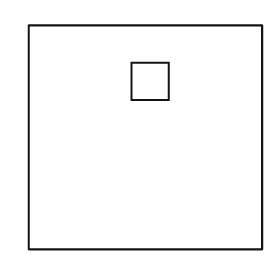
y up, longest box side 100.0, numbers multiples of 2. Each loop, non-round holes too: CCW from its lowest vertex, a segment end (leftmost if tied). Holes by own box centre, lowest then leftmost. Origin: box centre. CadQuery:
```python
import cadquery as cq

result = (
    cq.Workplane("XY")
    .moveTo(-50.0, -48.0)
    .lineTo(50.0, -48.0)
    .lineTo(50.0, 48.0)
    .lineTo(-50.0, 48.0)
    .close()
    .moveTo(-6.0, 16.0)
    .lineTo(10.0, 16.0)
    .lineTo(10.0, 32.0)
    .lineTo(-6.0, 32.0)
    .close()
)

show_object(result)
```